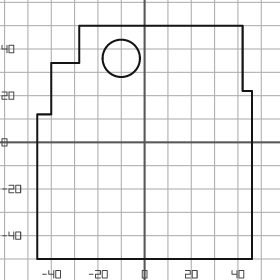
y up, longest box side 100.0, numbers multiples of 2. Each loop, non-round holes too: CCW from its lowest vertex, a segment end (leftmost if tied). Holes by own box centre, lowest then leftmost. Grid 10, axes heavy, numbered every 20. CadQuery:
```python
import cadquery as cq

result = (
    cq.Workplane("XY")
    .moveTo(-46.0, -50.0)
    .lineTo(46.0, -50.0)
    .lineTo(46.0, 22.0)
    .lineTo(42.0, 22.0)
    .lineTo(42.0, 50.0)
    .lineTo(-28.0, 50.0)
    .lineTo(-28.0, 34.0)
    .lineTo(-40.0, 34.0)
    .lineTo(-40.0, 12.0)
    .lineTo(-46.0, 12.0)
    .close()
    .moveTo(-10.0, 36.0)
    .circle(8.0)
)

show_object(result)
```